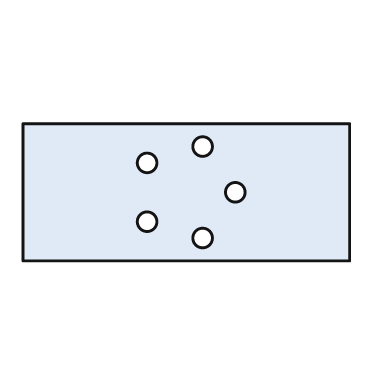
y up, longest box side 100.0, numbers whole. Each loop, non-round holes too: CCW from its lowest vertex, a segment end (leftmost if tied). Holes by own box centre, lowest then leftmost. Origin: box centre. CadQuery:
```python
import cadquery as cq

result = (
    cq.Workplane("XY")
    .moveTo(-50.0, -21.0)
    .lineTo(50.0, -21.0)
    .lineTo(50.0, 21.0)
    .lineTo(-50.0, 21.0)
    .close()
    .moveTo(5.0, -14.0)
    .circle(3.0)
    .moveTo(-12.0, -9.0)
    .circle(3.0)
    .moveTo(15.0, 0.0)
    .circle(3.0)
    .moveTo(-12.0, 9.0)
    .circle(3.0)
    .moveTo(5.0, 14.0)
    .circle(3.0)
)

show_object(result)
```